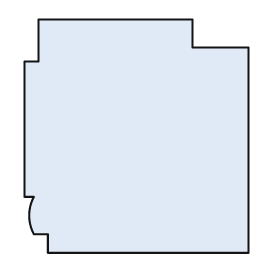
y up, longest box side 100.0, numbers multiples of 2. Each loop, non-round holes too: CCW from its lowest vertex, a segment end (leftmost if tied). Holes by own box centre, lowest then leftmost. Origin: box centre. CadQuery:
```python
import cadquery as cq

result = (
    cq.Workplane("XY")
    .moveTo(-38.0, -50.0)
    .lineTo(48.0, -50.0)
    .lineTo(48.0, 38.0)
    .lineTo(24.0, 38.0)
    .lineTo(24.0, 50.0)
    .lineTo(-42.0, 50.0)
    .lineTo(-42.0, 32.0)
    .lineTo(-48.0, 32.0)
    .lineTo(-48.0, -26.0)
    .lineTo(-44.0, -26.0)
    .threePointArc((-46.0, -34.0), (-44.0, -42.0))
    .lineTo(-38.0, -42.0)
    .close()
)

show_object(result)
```